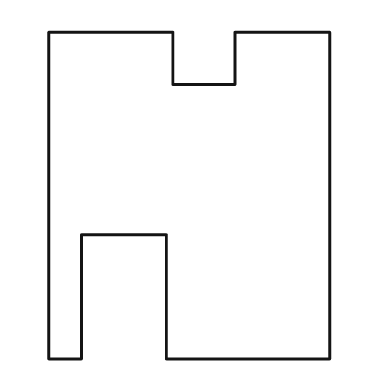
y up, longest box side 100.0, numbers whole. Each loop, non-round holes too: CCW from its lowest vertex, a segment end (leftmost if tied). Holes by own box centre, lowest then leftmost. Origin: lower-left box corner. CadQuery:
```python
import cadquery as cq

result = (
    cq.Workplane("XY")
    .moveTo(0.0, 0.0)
    .lineTo(10.0, 0.0)
    .lineTo(10.0, 38.0)
    .lineTo(36.0, 38.0)
    .lineTo(36.0, 0.0)
    .lineTo(86.0, 0.0)
    .lineTo(86.0, 100.0)
    .lineTo(57.0, 100.0)
    .lineTo(57.0, 84.0)
    .lineTo(38.0, 84.0)
    .lineTo(38.0, 100.0)
    .lineTo(0.0, 100.0)
    .close()
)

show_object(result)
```